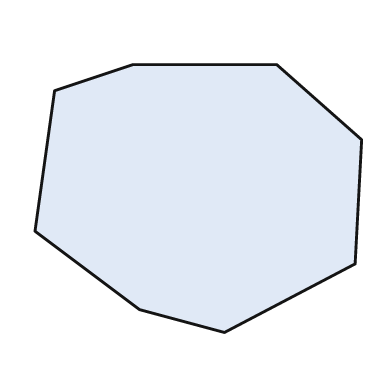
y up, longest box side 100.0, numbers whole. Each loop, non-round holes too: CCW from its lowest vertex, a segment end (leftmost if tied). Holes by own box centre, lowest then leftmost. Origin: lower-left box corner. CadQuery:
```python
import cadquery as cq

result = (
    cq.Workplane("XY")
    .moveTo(58.0, 0.0)
    .lineTo(98.0, 21.0)
    .lineTo(100.0, 59.0)
    .lineTo(74.0, 82.0)
    .lineTo(30.0, 82.0)
    .lineTo(6.0, 74.0)
    .lineTo(0.0, 31.0)
    .lineTo(32.0, 7.0)
    .close()
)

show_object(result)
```